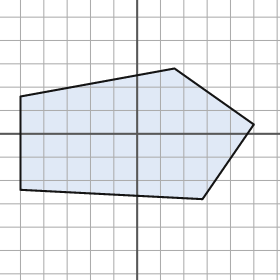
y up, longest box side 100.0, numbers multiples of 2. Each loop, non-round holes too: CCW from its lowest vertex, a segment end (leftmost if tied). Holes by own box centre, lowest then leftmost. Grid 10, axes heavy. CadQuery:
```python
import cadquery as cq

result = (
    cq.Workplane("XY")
    .moveTo(28.0, -28.0)
    .lineTo(50.0, 4.0)
    .lineTo(16.0, 28.0)
    .lineTo(-50.0, 16.0)
    .lineTo(-50.0, -24.0)
    .close()
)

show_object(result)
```